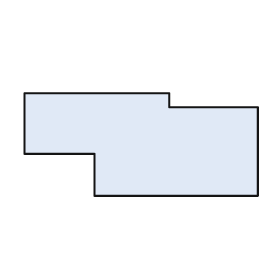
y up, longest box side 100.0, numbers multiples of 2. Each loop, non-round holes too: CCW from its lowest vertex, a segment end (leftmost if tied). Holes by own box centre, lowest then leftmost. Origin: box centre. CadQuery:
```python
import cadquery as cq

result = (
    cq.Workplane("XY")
    .moveTo(-20.0, -22.0)
    .lineTo(50.0, -22.0)
    .lineTo(50.0, 16.0)
    .lineTo(12.0, 16.0)
    .lineTo(12.0, 22.0)
    .lineTo(-50.0, 22.0)
    .lineTo(-50.0, -4.0)
    .lineTo(-20.0, -4.0)
    .close()
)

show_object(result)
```